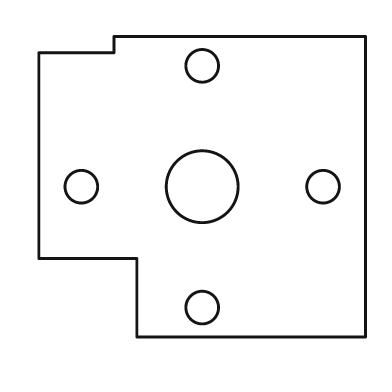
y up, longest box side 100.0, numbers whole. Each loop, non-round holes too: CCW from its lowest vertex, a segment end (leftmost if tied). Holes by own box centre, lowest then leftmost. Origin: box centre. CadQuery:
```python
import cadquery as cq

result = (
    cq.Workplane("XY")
    .moveTo(-20.0, -46.0)
    .lineTo(50.0, -46.0)
    .lineTo(50.0, 46.0)
    .lineTo(-27.0, 46.0)
    .lineTo(-27.0, 41.0)
    .lineTo(-50.0, 41.0)
    .lineTo(-50.0, -22.0)
    .lineTo(-20.0, -22.0)
    .close()
    .moveTo(0.0, -37.0)
    .circle(5.0)
    .moveTo(-37.0, 0.0)
    .circle(5.0)
    .moveTo(0.0, 0.0)
    .circle(11.0)
    .moveTo(37.0, 0.0)
    .circle(5.0)
    .moveTo(0.0, 37.0)
    .circle(5.0)
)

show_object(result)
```